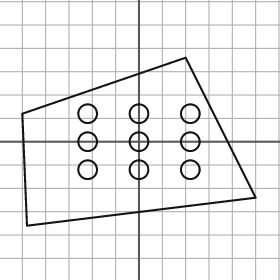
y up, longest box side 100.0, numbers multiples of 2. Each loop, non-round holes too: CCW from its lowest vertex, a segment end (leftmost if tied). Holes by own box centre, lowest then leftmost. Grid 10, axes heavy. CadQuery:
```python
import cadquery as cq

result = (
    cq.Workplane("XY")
    .moveTo(-48.0, -36.0)
    .lineTo(50.0, -24.0)
    .lineTo(20.0, 36.0)
    .lineTo(-50.0, 12.0)
    .close()
    .moveTo(-22.0, -12.0)
    .circle(4.0)
    .moveTo(0.0, -12.0)
    .circle(4.0)
    .moveTo(22.0, -12.0)
    .circle(4.0)
    .moveTo(-22.0, 0.0)
    .circle(4.0)
    .moveTo(0.0, 0.0)
    .circle(4.0)
    .moveTo(22.0, 0.0)
    .circle(4.0)
    .moveTo(-22.0, 12.0)
    .circle(4.0)
    .moveTo(0.0, 12.0)
    .circle(4.0)
    .moveTo(22.0, 12.0)
    .circle(4.0)
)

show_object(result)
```